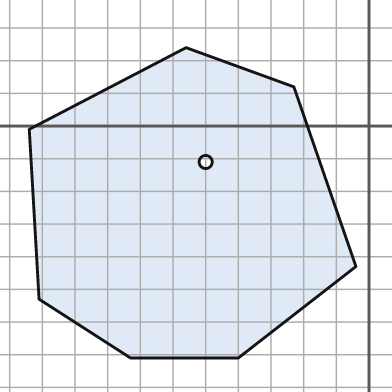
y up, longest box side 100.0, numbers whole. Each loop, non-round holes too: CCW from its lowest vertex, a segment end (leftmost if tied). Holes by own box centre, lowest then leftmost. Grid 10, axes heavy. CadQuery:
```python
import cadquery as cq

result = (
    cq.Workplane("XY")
    .moveTo(-73.0, -71.0)
    .lineTo(-40.0, -71.0)
    .lineTo(-4.0, -43.0)
    .lineTo(-23.0, 12.0)
    .lineTo(-56.0, 24.0)
    .lineTo(-104.0, -1.0)
    .lineTo(-101.0, -53.0)
    .close()
    .moveTo(-50.0, -11.0)
    .circle(2.0)
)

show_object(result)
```